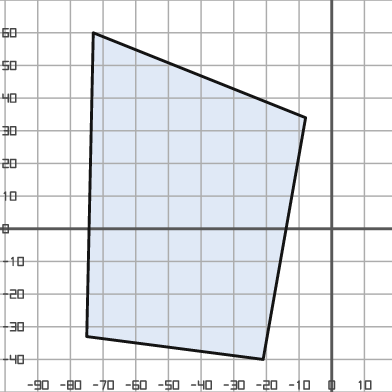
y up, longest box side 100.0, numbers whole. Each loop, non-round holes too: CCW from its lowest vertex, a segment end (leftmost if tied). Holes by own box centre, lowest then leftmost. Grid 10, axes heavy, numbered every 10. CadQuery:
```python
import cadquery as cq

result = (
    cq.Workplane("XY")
    .moveTo(-21.0, -40.0)
    .lineTo(-8.0, 34.0)
    .lineTo(-73.0, 60.0)
    .lineTo(-75.0, -33.0)
    .close()
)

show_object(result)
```